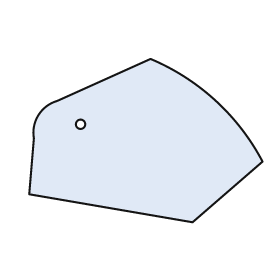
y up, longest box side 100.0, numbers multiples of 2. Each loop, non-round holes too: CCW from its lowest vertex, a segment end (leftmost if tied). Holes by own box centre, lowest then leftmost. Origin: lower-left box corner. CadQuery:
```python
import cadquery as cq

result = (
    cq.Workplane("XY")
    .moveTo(70.0, 0.0)
    .lineTo(100.0, 26.0)
    .threePointArc((80.0, 52.0), (52.0, 70.0))
    .lineTo(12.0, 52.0)
    .threePointArc((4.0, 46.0), (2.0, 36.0))
    .lineTo(0.0, 12.0)
    .close()
    .moveTo(22.0, 42.0)
    .circle(2.0)
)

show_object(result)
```